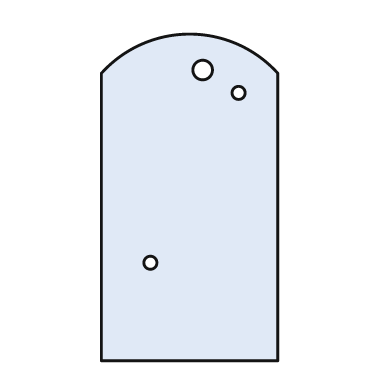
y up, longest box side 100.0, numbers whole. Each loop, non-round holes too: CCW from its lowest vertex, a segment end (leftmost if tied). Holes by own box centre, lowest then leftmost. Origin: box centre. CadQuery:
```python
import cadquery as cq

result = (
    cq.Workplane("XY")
    .moveTo(-27.0, -50.0)
    .lineTo(27.0, -50.0)
    .lineTo(27.0, 38.0)
    .threePointArc((0.0, 50.0), (-27.0, 38.0))
    .close()
    .moveTo(-12.0, -20.0)
    .circle(2.0)
    .moveTo(15.0, 32.0)
    .circle(2.0)
    .moveTo(4.0, 39.0)
    .circle(3.0)
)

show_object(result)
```